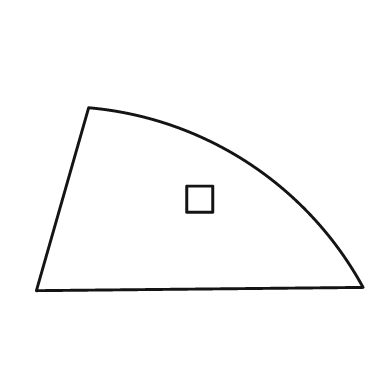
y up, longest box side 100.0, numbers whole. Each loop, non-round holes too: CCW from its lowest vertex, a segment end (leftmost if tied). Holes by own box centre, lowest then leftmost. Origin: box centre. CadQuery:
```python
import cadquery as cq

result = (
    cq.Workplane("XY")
    .moveTo(-50.0, -28.0)
    .lineTo(50.0, -27.0)
    .threePointArc((15.0, 11.0), (-34.0, 28.0))
    .close()
    .moveTo(-4.0, -4.0)
    .lineTo(4.0, -4.0)
    .lineTo(4.0, 4.0)
    .lineTo(-4.0, 4.0)
    .close()
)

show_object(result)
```